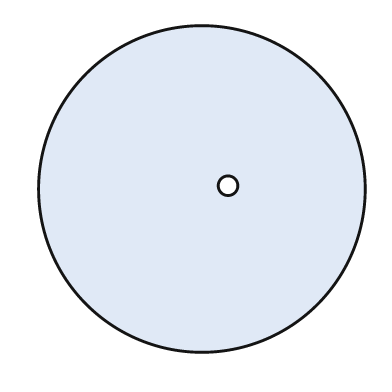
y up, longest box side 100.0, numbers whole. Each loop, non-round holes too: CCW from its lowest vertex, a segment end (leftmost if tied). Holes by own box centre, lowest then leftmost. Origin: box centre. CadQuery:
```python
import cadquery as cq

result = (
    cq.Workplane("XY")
    .moveTo(0.0, 0.0)
    .circle(50.0)
    .moveTo(8.0, 1.0)
    .circle(3.0)
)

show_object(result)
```